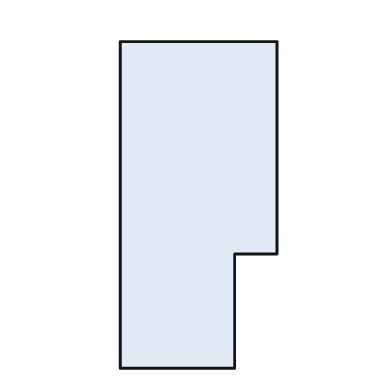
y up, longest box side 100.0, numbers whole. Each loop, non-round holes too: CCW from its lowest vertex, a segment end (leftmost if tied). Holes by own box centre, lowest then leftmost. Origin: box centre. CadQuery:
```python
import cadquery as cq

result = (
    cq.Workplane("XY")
    .moveTo(-24.0, -50.0)
    .lineTo(11.0, -50.0)
    .lineTo(11.0, -15.0)
    .lineTo(24.0, -15.0)
    .lineTo(24.0, 50.0)
    .lineTo(-24.0, 50.0)
    .close()
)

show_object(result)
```